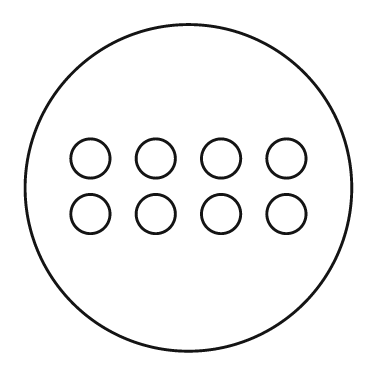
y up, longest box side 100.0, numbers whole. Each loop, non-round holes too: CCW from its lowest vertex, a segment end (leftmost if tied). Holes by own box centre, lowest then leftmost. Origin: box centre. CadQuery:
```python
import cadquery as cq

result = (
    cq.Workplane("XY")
    .moveTo(0.0, 0.0)
    .circle(50.0)
    .moveTo(-30.0, -8.0)
    .circle(6.0)
    .moveTo(-10.0, -8.0)
    .circle(6.0)
    .moveTo(10.0, -8.0)
    .circle(6.0)
    .moveTo(30.0, -8.0)
    .circle(6.0)
    .moveTo(-30.0, 9.0)
    .circle(6.0)
    .moveTo(-10.0, 9.0)
    .circle(6.0)
    .moveTo(10.0, 9.0)
    .circle(6.0)
    .moveTo(30.0, 9.0)
    .circle(6.0)
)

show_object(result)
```